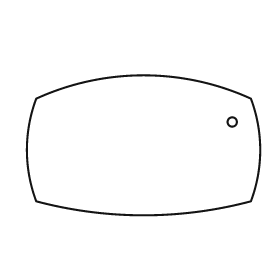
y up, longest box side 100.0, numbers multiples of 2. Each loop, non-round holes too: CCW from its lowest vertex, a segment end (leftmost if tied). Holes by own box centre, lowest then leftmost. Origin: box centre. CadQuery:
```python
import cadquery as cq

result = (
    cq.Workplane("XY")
    .moveTo(-46.0, -24.0)
    .threePointArc((0.0, -30.0), (46.0, -24.0))
    .threePointArc((50.0, -2.0), (46.0, 20.0))
    .threePointArc((0.0, 30.0), (-46.0, 20.0))
    .threePointArc((-50.0, -2.0), (-46.0, -24.0))
    .close()
    .moveTo(38.0, 10.0)
    .circle(2.0)
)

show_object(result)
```